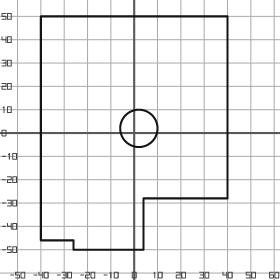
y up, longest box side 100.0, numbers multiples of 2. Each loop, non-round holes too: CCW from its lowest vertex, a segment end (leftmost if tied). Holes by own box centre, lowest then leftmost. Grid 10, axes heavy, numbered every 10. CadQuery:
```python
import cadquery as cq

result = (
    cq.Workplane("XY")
    .moveTo(-26.0, -50.0)
    .lineTo(4.0, -50.0)
    .lineTo(4.0, -28.0)
    .lineTo(40.0, -28.0)
    .lineTo(40.0, 50.0)
    .lineTo(-40.0, 50.0)
    .lineTo(-40.0, -46.0)
    .lineTo(-26.0, -46.0)
    .close()
    .moveTo(2.0, 2.0)
    .circle(8.0)
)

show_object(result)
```